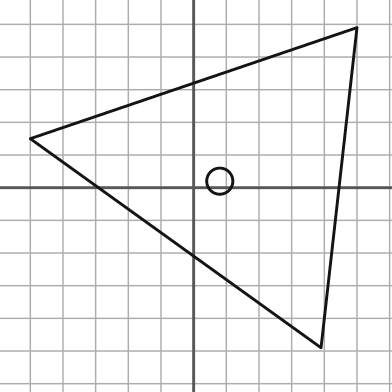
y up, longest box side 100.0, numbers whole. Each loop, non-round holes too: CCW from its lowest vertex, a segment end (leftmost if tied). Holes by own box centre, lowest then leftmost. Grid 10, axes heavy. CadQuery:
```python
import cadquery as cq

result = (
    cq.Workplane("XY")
    .moveTo(39.0, -49.0)
    .lineTo(50.0, 49.0)
    .lineTo(-50.0, 15.0)
    .close()
    .moveTo(8.0, 2.0)
    .circle(4.0)
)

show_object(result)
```